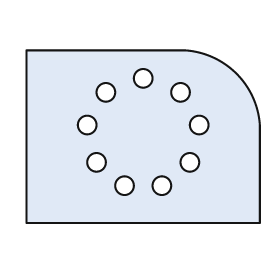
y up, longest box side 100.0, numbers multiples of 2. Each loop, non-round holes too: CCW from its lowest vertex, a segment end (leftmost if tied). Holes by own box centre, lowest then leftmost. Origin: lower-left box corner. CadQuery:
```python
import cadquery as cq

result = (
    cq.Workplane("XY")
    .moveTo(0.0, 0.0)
    .lineTo(100.0, 0.0)
    .lineTo(100.0, 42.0)
    .threePointArc((90.0, 64.0), (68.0, 74.0))
    .lineTo(0.0, 74.0)
    .close()
    .moveTo(42.0, 16.0)
    .circle(4.0)
    .moveTo(58.0, 16.0)
    .circle(4.0)
    .moveTo(30.0, 26.0)
    .circle(4.0)
    .moveTo(70.0, 26.0)
    .circle(4.0)
    .moveTo(26.0, 42.0)
    .circle(4.0)
    .moveTo(74.0, 42.0)
    .circle(4.0)
    .moveTo(34.0, 56.0)
    .circle(4.0)
    .moveTo(66.0, 56.0)
    .circle(4.0)
    .moveTo(50.0, 62.0)
    .circle(4.0)
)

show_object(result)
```